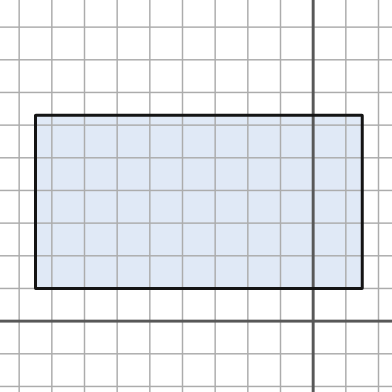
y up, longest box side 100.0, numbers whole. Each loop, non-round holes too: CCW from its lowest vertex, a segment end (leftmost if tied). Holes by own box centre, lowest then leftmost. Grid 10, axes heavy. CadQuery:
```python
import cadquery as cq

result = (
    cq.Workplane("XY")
    .moveTo(-85.0, 10.0)
    .lineTo(15.0, 10.0)
    .lineTo(15.0, 63.0)
    .lineTo(-85.0, 63.0)
    .close()
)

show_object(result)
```